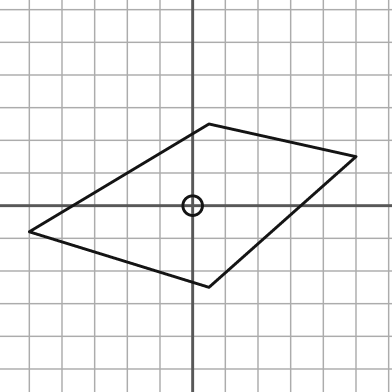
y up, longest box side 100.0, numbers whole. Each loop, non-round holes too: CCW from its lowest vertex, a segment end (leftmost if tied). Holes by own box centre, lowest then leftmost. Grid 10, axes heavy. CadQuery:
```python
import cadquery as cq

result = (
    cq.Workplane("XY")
    .moveTo(5.0, -25.0)
    .lineTo(50.0, 15.0)
    .lineTo(5.0, 25.0)
    .lineTo(-50.0, -8.0)
    .close()
    .moveTo(0.0, 0.0)
    .circle(3.0)
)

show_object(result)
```